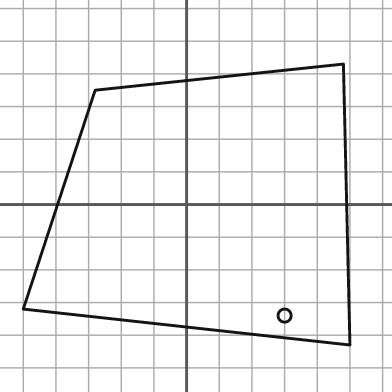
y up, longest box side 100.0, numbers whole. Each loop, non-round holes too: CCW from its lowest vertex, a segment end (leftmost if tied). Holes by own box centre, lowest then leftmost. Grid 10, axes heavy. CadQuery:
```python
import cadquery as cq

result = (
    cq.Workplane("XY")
    .moveTo(50.0, -43.0)
    .lineTo(48.0, 43.0)
    .lineTo(-28.0, 35.0)
    .lineTo(-50.0, -32.0)
    .close()
    .moveTo(30.0, -34.0)
    .circle(2.0)
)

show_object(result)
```